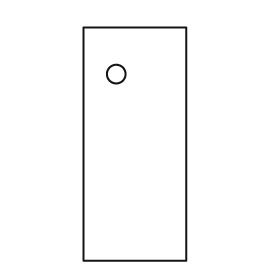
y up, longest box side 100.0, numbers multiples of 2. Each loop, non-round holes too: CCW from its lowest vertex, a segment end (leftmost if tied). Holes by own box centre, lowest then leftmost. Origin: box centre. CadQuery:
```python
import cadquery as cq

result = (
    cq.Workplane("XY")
    .moveTo(-22.0, -50.0)
    .lineTo(22.0, -50.0)
    .lineTo(22.0, 50.0)
    .lineTo(-22.0, 50.0)
    .close()
    .moveTo(-8.0, 30.0)
    .circle(4.0)
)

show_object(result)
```